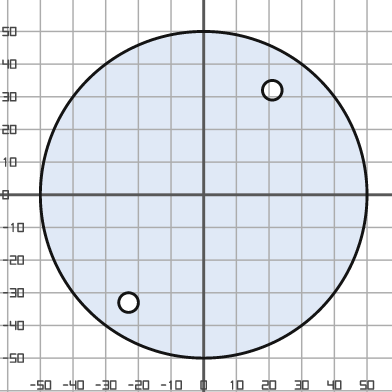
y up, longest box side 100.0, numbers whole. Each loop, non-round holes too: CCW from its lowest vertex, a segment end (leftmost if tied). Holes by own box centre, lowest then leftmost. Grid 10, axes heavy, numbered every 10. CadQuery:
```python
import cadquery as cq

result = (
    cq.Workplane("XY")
    .moveTo(0.0, 0.0)
    .circle(50.0)
    .moveTo(-23.0, -33.0)
    .circle(3.0)
    .moveTo(21.0, 32.0)
    .circle(3.0)
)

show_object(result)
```